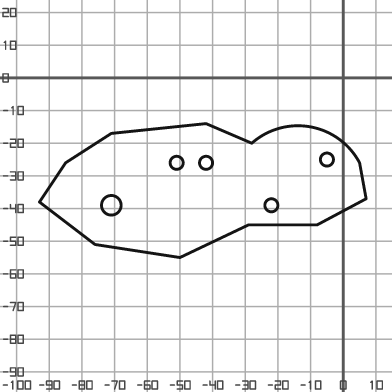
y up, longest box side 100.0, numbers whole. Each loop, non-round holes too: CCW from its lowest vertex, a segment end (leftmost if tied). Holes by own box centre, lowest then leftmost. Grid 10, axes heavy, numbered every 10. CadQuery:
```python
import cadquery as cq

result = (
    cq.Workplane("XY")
    .moveTo(-50.0, -55.0)
    .lineTo(-29.0, -45.0)
    .lineTo(-8.0, -45.0)
    .lineTo(7.0, -37.0)
    .lineTo(5.0, -26.0)
    .threePointArc((-10.0, -15.0), (-28.0, -20.0))
    .lineTo(-42.0, -14.0)
    .lineTo(-71.0, -17.0)
    .lineTo(-85.0, -26.0)
    .lineTo(-93.0, -38.0)
    .lineTo(-76.0, -51.0)
    .close()
    .moveTo(-71.0, -39.0)
    .circle(3.0)
    .moveTo(-22.0, -39.0)
    .circle(2.0)
    .moveTo(-51.0, -26.0)
    .circle(2.0)
    .moveTo(-42.0, -26.0)
    .circle(2.0)
    .moveTo(-5.0, -25.0)
    .circle(2.0)
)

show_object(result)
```